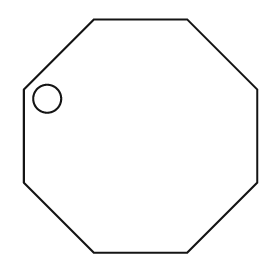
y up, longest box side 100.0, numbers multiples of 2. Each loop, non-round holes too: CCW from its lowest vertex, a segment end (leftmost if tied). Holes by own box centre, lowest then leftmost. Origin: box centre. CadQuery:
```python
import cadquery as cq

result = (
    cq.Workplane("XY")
    .moveTo(-20.0, -50.0)
    .lineTo(20.0, -50.0)
    .lineTo(50.0, -20.0)
    .lineTo(50.0, 20.0)
    .lineTo(20.0, 50.0)
    .lineTo(-20.0, 50.0)
    .lineTo(-50.0, 20.0)
    .lineTo(-50.0, -20.0)
    .close()
    .moveTo(-40.0, 16.0)
    .circle(6.0)
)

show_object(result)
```